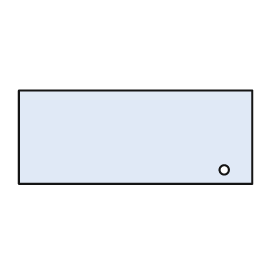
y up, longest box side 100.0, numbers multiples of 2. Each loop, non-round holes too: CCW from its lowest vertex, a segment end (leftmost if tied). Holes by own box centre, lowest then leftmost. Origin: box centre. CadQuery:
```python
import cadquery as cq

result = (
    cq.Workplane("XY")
    .moveTo(-50.0, -20.0)
    .lineTo(50.0, -20.0)
    .lineTo(50.0, 20.0)
    .lineTo(-50.0, 20.0)
    .close()
    .moveTo(38.0, -14.0)
    .circle(2.0)
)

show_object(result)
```